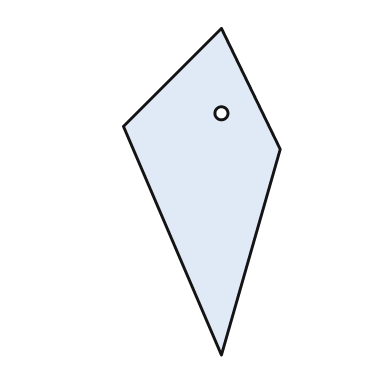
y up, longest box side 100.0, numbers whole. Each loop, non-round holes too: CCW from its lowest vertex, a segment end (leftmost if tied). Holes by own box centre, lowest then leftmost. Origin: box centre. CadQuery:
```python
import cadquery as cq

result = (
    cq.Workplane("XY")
    .moveTo(6.0, -50.0)
    .lineTo(24.0, 13.0)
    .lineTo(6.0, 50.0)
    .lineTo(-24.0, 20.0)
    .close()
    .moveTo(6.0, 24.0)
    .circle(2.0)
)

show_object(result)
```